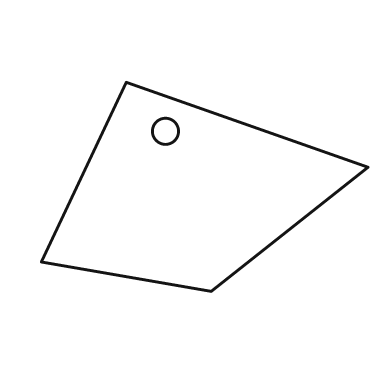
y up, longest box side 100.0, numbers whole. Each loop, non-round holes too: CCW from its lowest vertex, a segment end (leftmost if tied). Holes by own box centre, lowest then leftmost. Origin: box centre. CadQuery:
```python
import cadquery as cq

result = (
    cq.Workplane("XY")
    .moveTo(2.0, -32.0)
    .lineTo(50.0, 6.0)
    .lineTo(-24.0, 32.0)
    .lineTo(-50.0, -23.0)
    .close()
    .moveTo(-12.0, 17.0)
    .circle(4.0)
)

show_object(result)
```